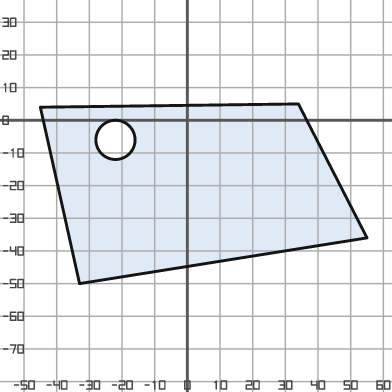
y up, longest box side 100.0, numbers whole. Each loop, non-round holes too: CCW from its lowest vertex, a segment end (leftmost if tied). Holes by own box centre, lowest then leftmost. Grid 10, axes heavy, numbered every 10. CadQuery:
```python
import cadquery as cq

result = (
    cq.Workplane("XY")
    .moveTo(-33.0, -50.0)
    .lineTo(55.0, -36.0)
    .lineTo(34.0, 5.0)
    .lineTo(-45.0, 4.0)
    .close()
    .moveTo(-22.0, -6.0)
    .circle(6.0)
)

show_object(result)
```